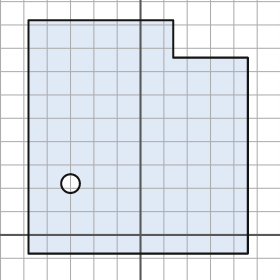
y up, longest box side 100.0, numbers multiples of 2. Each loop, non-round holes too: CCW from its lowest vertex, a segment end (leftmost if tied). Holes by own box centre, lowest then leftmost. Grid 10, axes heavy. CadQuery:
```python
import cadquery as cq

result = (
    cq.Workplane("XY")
    .moveTo(-48.0, -8.0)
    .lineTo(46.0, -8.0)
    .lineTo(46.0, 76.0)
    .lineTo(14.0, 76.0)
    .lineTo(14.0, 92.0)
    .lineTo(-48.0, 92.0)
    .close()
    .moveTo(-30.0, 22.0)
    .circle(4.0)
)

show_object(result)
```